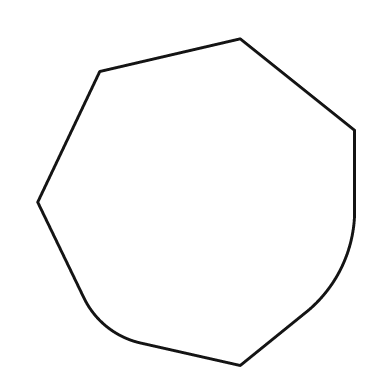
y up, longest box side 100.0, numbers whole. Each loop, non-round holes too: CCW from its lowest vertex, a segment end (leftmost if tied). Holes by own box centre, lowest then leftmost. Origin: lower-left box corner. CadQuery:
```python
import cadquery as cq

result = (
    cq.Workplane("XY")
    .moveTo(62.0, 0.0)
    .lineTo(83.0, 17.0)
    .threePointArc((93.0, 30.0), (97.0, 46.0))
    .lineTo(97.0, 72.0)
    .lineTo(62.0, 100.0)
    .lineTo(19.0, 90.0)
    .lineTo(0.0, 50.0)
    .lineTo(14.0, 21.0)
    .threePointArc((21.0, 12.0), (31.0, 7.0))
    .close()
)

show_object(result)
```